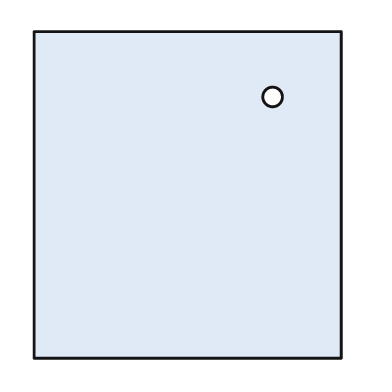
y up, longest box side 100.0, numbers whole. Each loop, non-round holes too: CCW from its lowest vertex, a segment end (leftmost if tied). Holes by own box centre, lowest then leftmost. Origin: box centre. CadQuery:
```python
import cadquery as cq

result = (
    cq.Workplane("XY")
    .moveTo(-47.0, -50.0)
    .lineTo(47.0, -50.0)
    .lineTo(47.0, 50.0)
    .lineTo(-47.0, 50.0)
    .close()
    .moveTo(26.0, 30.0)
    .circle(3.0)
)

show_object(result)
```